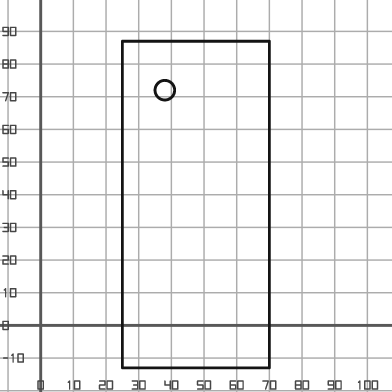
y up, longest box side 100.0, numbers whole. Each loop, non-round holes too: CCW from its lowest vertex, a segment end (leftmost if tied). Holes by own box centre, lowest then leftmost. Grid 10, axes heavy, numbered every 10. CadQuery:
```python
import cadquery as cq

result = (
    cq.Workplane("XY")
    .moveTo(25.0, -13.0)
    .lineTo(70.0, -13.0)
    .lineTo(70.0, 87.0)
    .lineTo(25.0, 87.0)
    .close()
    .moveTo(38.0, 72.0)
    .circle(3.0)
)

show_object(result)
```